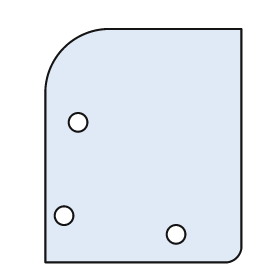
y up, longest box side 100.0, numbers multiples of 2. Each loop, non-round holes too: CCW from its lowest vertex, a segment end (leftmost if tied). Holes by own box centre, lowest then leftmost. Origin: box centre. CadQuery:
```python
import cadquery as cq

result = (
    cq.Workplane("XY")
    .moveTo(-42.0, -50.0)
    .lineTo(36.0, -50.0)
    .threePointArc((40.0, -48.0), (42.0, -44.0))
    .lineTo(42.0, 50.0)
    .lineTo(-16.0, 50.0)
    .threePointArc((-34.0, 42.0), (-42.0, 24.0))
    .close()
    .moveTo(14.0, -38.0)
    .circle(4.0)
    .moveTo(-34.0, -30.0)
    .circle(4.0)
    .moveTo(-28.0, 10.0)
    .circle(4.0)
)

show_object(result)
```